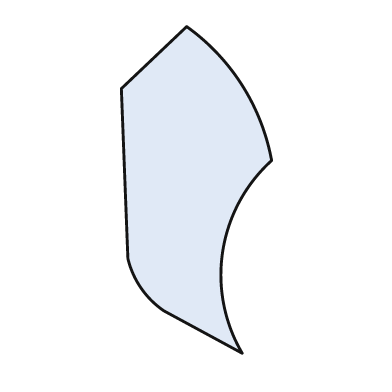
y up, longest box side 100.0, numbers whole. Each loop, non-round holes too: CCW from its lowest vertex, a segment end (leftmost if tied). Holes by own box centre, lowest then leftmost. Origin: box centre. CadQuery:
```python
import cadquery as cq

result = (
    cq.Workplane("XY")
    .moveTo(14.0, -50.0)
    .threePointArc((8.0, -19.0), (23.0, 9.0))
    .threePointArc((14.0, 32.0), (-3.0, 50.0))
    .lineTo(-23.0, 31.0)
    .lineTo(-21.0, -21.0)
    .threePointArc((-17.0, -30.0), (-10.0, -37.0))
    .close()
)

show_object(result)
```